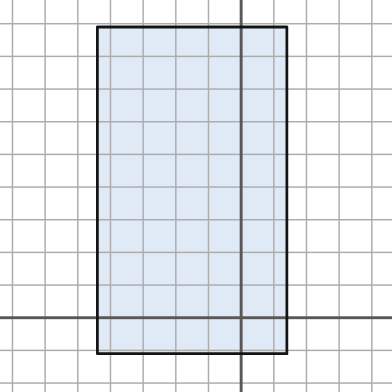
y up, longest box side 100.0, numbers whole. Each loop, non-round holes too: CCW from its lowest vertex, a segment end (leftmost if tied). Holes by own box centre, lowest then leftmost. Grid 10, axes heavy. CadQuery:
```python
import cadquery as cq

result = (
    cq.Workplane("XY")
    .moveTo(-44.0, -11.0)
    .lineTo(14.0, -11.0)
    .lineTo(14.0, 89.0)
    .lineTo(-44.0, 89.0)
    .close()
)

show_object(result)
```